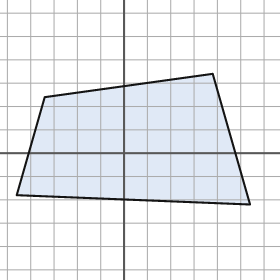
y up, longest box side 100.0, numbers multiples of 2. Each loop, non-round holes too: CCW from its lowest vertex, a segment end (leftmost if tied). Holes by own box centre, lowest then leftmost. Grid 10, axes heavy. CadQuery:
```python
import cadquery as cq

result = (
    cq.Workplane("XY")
    .moveTo(54.0, -22.0)
    .lineTo(38.0, 34.0)
    .lineTo(-34.0, 24.0)
    .lineTo(-46.0, -18.0)
    .close()
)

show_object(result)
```